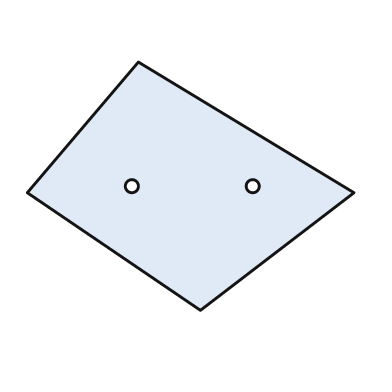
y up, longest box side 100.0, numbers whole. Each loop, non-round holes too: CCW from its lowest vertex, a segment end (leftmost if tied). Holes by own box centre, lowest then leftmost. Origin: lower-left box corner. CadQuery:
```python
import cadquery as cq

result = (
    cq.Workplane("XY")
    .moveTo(53.0, 0.0)
    .lineTo(100.0, 36.0)
    .lineTo(34.0, 76.0)
    .lineTo(0.0, 36.0)
    .close()
    .moveTo(32.0, 38.0)
    .circle(2.0)
    .moveTo(69.0, 38.0)
    .circle(2.0)
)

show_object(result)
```